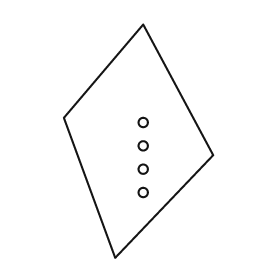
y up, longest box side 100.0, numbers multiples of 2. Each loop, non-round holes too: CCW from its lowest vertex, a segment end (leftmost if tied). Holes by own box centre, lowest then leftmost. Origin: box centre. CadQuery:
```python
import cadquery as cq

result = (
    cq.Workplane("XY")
    .moveTo(-10.0, -50.0)
    .lineTo(32.0, -6.0)
    .lineTo(2.0, 50.0)
    .lineTo(-32.0, 10.0)
    .close()
    .moveTo(2.0, -22.0)
    .circle(2.0)
    .moveTo(2.0, -12.0)
    .circle(2.0)
    .moveTo(2.0, -2.0)
    .circle(2.0)
    .moveTo(2.0, 8.0)
    .circle(2.0)
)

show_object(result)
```